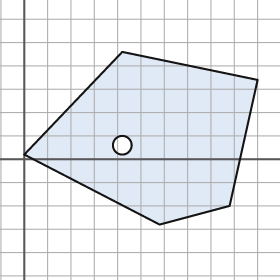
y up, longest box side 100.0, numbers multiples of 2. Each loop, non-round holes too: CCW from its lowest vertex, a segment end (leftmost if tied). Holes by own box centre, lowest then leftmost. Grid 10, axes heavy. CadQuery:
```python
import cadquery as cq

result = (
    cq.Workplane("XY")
    .moveTo(58.0, -28.0)
    .lineTo(88.0, -20.0)
    .lineTo(100.0, 34.0)
    .lineTo(42.0, 46.0)
    .lineTo(0.0, 2.0)
    .close()
    .moveTo(42.0, 6.0)
    .circle(4.0)
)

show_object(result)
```